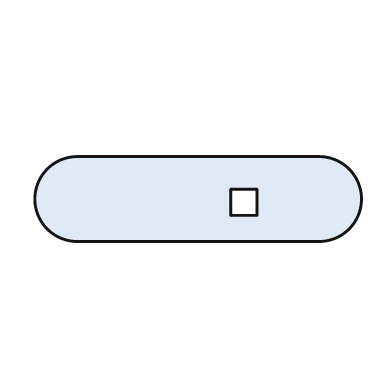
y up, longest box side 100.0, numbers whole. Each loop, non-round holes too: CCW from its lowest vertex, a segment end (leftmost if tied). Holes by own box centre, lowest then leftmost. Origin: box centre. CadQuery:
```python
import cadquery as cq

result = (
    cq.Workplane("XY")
    .moveTo(-37.0, -13.0)
    .lineTo(37.0, -13.0)
    .threePointArc((50.0, 0.0), (37.0, 13.0))
    .lineTo(-37.0, 13.0)
    .threePointArc((-50.0, 0.0), (-37.0, -13.0))
    .close()
    .moveTo(10.0, -5.0)
    .lineTo(18.0, -5.0)
    .lineTo(18.0, 3.0)
    .lineTo(10.0, 3.0)
    .close()
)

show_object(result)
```